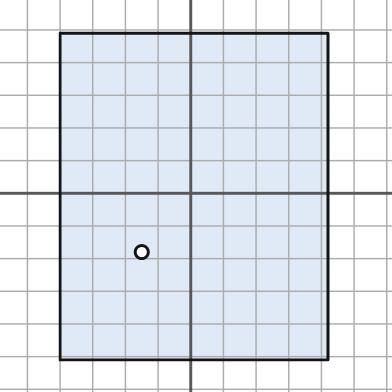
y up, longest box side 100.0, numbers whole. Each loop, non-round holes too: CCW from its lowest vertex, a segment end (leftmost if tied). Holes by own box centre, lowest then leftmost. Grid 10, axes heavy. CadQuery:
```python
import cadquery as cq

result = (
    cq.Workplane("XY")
    .moveTo(-40.0, -51.0)
    .lineTo(42.0, -51.0)
    .lineTo(42.0, 49.0)
    .lineTo(-40.0, 49.0)
    .close()
    .moveTo(-15.0, -18.0)
    .circle(2.0)
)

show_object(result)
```